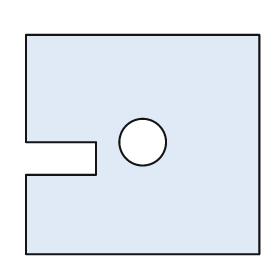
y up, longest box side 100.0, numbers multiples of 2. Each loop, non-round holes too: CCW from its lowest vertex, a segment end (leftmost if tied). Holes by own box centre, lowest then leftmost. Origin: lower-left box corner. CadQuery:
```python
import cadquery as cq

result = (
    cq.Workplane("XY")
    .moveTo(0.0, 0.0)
    .lineTo(100.0, 0.0)
    .lineTo(100.0, 94.0)
    .lineTo(0.0, 94.0)
    .lineTo(0.0, 48.0)
    .lineTo(30.0, 48.0)
    .lineTo(30.0, 34.0)
    .lineTo(0.0, 34.0)
    .close()
    .moveTo(50.0, 48.0)
    .circle(10.0)
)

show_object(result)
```